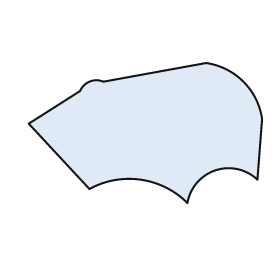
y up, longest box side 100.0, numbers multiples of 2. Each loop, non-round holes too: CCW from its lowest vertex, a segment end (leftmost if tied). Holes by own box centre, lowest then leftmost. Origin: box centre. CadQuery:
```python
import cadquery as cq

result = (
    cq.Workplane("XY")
    .moveTo(18.0, -30.0)
    .threePointArc((30.0, -16.0), (48.0, -20.0))
    .lineTo(50.0, 6.0)
    .threePointArc((42.0, 22.0), (26.0, 30.0))
    .lineTo(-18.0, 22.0)
    .threePointArc((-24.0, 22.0), (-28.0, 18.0))
    .lineTo(-50.0, 4.0)
    .lineTo(-24.0, -24.0)
    .threePointArc((-2.0, -20.0), (18.0, -30.0))
    .close()
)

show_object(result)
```